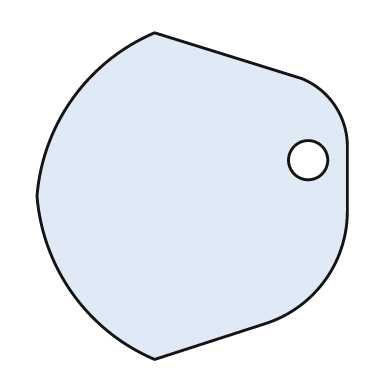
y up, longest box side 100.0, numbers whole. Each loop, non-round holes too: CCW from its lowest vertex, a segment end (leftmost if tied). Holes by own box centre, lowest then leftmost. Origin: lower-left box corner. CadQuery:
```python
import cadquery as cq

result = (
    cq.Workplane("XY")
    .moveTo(36.0, 0.0)
    .lineTo(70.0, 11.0)
    .threePointArc((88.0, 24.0), (95.0, 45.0))
    .lineTo(95.0, 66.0)
    .threePointArc((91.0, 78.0), (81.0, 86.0))
    .lineTo(36.0, 100.0)
    .threePointArc((11.0, 80.0), (0.0, 50.0))
    .threePointArc((11.0, 20.0), (36.0, 0.0))
    .close()
    .moveTo(83.0, 61.0)
    .circle(6.0)
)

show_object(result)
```